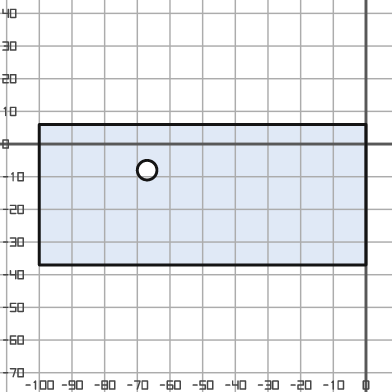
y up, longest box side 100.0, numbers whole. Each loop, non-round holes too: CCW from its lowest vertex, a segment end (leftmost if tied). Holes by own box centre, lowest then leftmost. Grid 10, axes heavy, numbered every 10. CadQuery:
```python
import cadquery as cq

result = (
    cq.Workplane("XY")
    .moveTo(-100.0, -37.0)
    .lineTo(0.0, -37.0)
    .lineTo(0.0, 6.0)
    .lineTo(-100.0, 6.0)
    .close()
    .moveTo(-67.0, -8.0)
    .circle(3.0)
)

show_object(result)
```